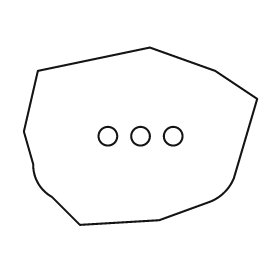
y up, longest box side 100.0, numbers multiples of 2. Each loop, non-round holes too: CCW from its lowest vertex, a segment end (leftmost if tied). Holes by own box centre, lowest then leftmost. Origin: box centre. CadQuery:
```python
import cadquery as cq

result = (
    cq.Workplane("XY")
    .moveTo(-26.0, -38.0)
    .lineTo(8.0, -36.0)
    .lineTo(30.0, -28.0)
    .threePointArc((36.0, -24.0), (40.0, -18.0))
    .lineTo(50.0, 16.0)
    .lineTo(32.0, 28.0)
    .lineTo(4.0, 38.0)
    .lineTo(-44.0, 28.0)
    .lineTo(-50.0, 2.0)
    .lineTo(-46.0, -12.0)
    .threePointArc((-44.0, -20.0), (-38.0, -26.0))
    .close()
    .moveTo(-14.0, 0.0)
    .circle(4.0)
    .moveTo(0.0, 0.0)
    .circle(4.0)
    .moveTo(14.0, 0.0)
    .circle(4.0)
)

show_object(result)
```